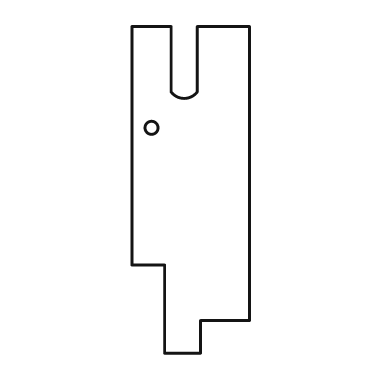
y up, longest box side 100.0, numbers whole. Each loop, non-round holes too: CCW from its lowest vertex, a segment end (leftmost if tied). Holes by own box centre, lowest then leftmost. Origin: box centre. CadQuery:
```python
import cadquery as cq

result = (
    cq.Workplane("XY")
    .moveTo(-8.0, -50.0)
    .lineTo(3.0, -50.0)
    .lineTo(3.0, -40.0)
    .lineTo(18.0, -40.0)
    .lineTo(18.0, 50.0)
    .lineTo(2.0, 50.0)
    .lineTo(2.0, 30.0)
    .threePointArc((-2.0, 28.0), (-6.0, 30.0))
    .lineTo(-6.0, 50.0)
    .lineTo(-18.0, 50.0)
    .lineTo(-18.0, -23.0)
    .lineTo(-8.0, -23.0)
    .close()
    .moveTo(-12.0, 19.0)
    .circle(2.0)
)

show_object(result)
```